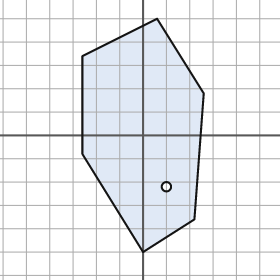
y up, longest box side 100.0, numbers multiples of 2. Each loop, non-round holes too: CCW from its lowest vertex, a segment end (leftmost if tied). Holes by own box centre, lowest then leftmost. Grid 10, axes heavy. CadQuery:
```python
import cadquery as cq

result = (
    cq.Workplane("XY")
    .moveTo(0.0, -50.0)
    .lineTo(22.0, -36.0)
    .lineTo(26.0, 18.0)
    .lineTo(6.0, 50.0)
    .lineTo(-26.0, 34.0)
    .lineTo(-26.0, -8.0)
    .close()
    .moveTo(10.0, -22.0)
    .circle(2.0)
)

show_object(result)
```